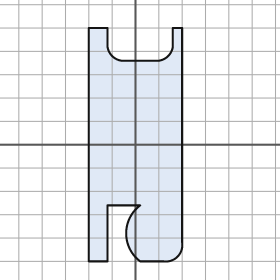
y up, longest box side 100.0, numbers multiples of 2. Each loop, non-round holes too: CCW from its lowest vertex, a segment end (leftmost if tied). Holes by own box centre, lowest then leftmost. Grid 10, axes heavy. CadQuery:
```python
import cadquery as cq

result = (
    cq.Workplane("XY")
    .moveTo(-20.0, -50.0)
    .lineTo(-12.0, -50.0)
    .lineTo(-12.0, -26.0)
    .lineTo(2.0, -26.0)
    .threePointArc((-4.0, -38.0), (2.0, -50.0))
    .lineTo(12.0, -50.0)
    .threePointArc((18.0, -48.0), (20.0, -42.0))
    .lineTo(20.0, 50.0)
    .lineTo(16.0, 50.0)
    .lineTo(16.0, 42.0)
    .threePointArc((14.0, 38.0), (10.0, 36.0))
    .lineTo(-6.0, 36.0)
    .threePointArc((-10.0, 38.0), (-12.0, 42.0))
    .lineTo(-12.0, 50.0)
    .lineTo(-20.0, 50.0)
    .close()
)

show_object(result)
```